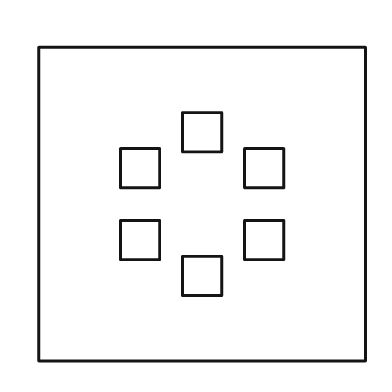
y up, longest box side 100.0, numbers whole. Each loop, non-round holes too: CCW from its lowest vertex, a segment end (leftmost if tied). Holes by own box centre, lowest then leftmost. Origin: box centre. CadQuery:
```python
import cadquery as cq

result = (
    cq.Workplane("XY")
    .moveTo(-50.0, -48.0)
    .lineTo(50.0, -48.0)
    .lineTo(50.0, 48.0)
    .lineTo(-50.0, 48.0)
    .close()
    .moveTo(-6.0, -28.0)
    .lineTo(6.0, -28.0)
    .lineTo(6.0, -16.0)
    .lineTo(-6.0, -16.0)
    .close()
    .moveTo(-25.0, -17.0)
    .lineTo(-13.0, -17.0)
    .lineTo(-13.0, -5.0)
    .lineTo(-25.0, -5.0)
    .close()
    .moveTo(13.0, -17.0)
    .lineTo(25.0, -17.0)
    .lineTo(25.0, -5.0)
    .lineTo(13.0, -5.0)
    .close()
    .moveTo(-25.0, 5.0)
    .lineTo(-13.0, 5.0)
    .lineTo(-13.0, 17.0)
    .lineTo(-25.0, 17.0)
    .close()
    .moveTo(13.0, 5.0)
    .lineTo(25.0, 5.0)
    .lineTo(25.0, 17.0)
    .lineTo(13.0, 17.0)
    .close()
    .moveTo(-6.0, 16.0)
    .lineTo(6.0, 16.0)
    .lineTo(6.0, 28.0)
    .lineTo(-6.0, 28.0)
    .close()
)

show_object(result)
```